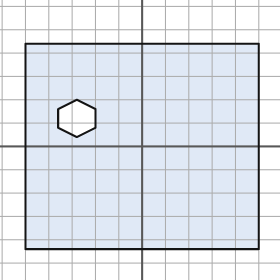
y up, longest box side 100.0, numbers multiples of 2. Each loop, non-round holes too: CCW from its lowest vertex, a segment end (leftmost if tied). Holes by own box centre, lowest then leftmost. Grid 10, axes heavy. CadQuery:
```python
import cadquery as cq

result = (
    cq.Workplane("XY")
    .moveTo(-50.0, -44.0)
    .lineTo(50.0, -44.0)
    .lineTo(50.0, 44.0)
    .lineTo(-50.0, 44.0)
    .close()
    .moveTo(-28.0, 4.0)
    .lineTo(-20.0, 8.0)
    .lineTo(-20.0, 16.0)
    .lineTo(-28.0, 20.0)
    .lineTo(-36.0, 16.0)
    .lineTo(-36.0, 8.0)
    .close()
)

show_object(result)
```